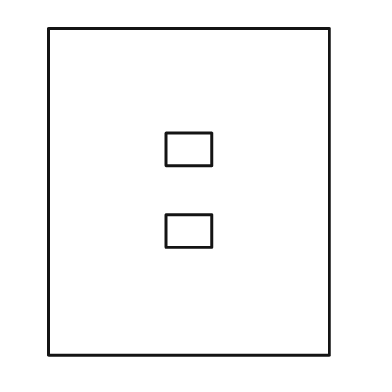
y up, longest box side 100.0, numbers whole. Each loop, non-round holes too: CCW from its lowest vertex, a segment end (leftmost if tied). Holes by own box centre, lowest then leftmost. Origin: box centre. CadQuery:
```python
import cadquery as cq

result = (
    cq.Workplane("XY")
    .moveTo(-43.0, -50.0)
    .lineTo(43.0, -50.0)
    .lineTo(43.0, 50.0)
    .lineTo(-43.0, 50.0)
    .close()
    .moveTo(-7.0, -17.0)
    .lineTo(7.0, -17.0)
    .lineTo(7.0, -7.0)
    .lineTo(-7.0, -7.0)
    .close()
    .moveTo(-7.0, 8.0)
    .lineTo(7.0, 8.0)
    .lineTo(7.0, 18.0)
    .lineTo(-7.0, 18.0)
    .close()
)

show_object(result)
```